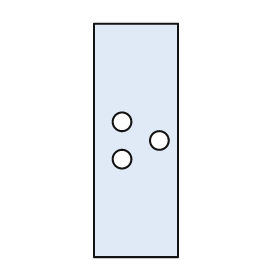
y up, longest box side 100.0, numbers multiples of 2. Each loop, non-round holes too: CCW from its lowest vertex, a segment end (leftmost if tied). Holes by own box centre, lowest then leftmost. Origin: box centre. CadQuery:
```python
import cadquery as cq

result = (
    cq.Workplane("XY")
    .moveTo(-18.0, -50.0)
    .lineTo(18.0, -50.0)
    .lineTo(18.0, 50.0)
    .lineTo(-18.0, 50.0)
    .close()
    .moveTo(-6.0, -8.0)
    .circle(4.0)
    .moveTo(10.0, 0.0)
    .circle(4.0)
    .moveTo(-6.0, 8.0)
    .circle(4.0)
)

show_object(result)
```